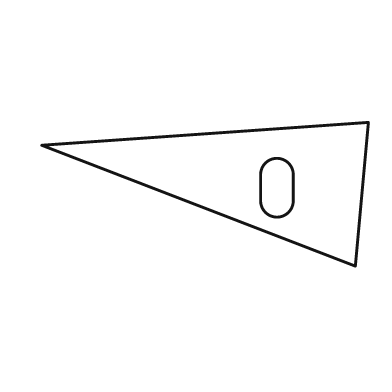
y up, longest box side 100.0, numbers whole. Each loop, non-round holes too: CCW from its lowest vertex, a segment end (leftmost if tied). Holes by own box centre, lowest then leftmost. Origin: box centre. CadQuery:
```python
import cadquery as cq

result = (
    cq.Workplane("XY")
    .moveTo(46.0, -22.0)
    .lineTo(50.0, 22.0)
    .lineTo(-50.0, 15.0)
    .close()
    .moveTo(17.0, -2.0)
    .threePointArc((22.0, -7.0), (27.0, -2.0))
    .lineTo(27.0, 6.0)
    .threePointArc((22.0, 11.0), (17.0, 6.0))
    .close()
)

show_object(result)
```